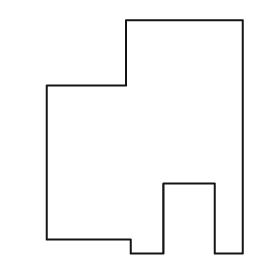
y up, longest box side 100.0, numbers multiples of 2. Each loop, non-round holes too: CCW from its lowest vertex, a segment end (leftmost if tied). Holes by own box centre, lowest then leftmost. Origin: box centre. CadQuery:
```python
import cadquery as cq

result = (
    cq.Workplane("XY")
    .moveTo(-6.0, -50.0)
    .lineTo(8.0, -50.0)
    .lineTo(8.0, -20.0)
    .lineTo(30.0, -20.0)
    .lineTo(30.0, -50.0)
    .lineTo(42.0, -50.0)
    .lineTo(42.0, 50.0)
    .lineTo(-8.0, 50.0)
    .lineTo(-8.0, 22.0)
    .lineTo(-42.0, 22.0)
    .lineTo(-42.0, -44.0)
    .lineTo(-6.0, -44.0)
    .close()
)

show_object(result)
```